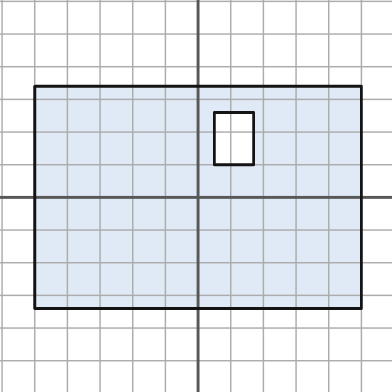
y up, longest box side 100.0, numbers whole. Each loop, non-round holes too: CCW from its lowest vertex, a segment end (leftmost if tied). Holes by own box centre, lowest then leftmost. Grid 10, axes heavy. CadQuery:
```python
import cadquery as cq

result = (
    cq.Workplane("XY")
    .moveTo(-50.0, -34.0)
    .lineTo(50.0, -34.0)
    .lineTo(50.0, 34.0)
    .lineTo(-50.0, 34.0)
    .close()
    .moveTo(5.0, 10.0)
    .lineTo(17.0, 10.0)
    .lineTo(17.0, 26.0)
    .lineTo(5.0, 26.0)
    .close()
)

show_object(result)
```